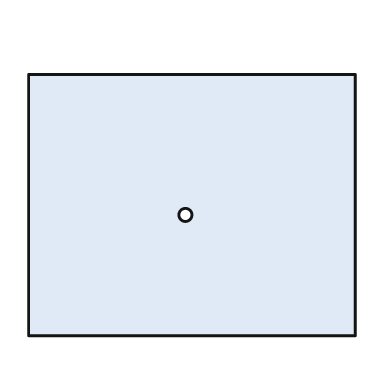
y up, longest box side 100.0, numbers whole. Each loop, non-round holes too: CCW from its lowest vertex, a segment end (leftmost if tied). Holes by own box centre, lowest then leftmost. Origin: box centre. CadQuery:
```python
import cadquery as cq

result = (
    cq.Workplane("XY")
    .moveTo(-50.0, -40.0)
    .lineTo(50.0, -40.0)
    .lineTo(50.0, 40.0)
    .lineTo(-50.0, 40.0)
    .close()
    .moveTo(-2.0, -3.0)
    .circle(2.0)
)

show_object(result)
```